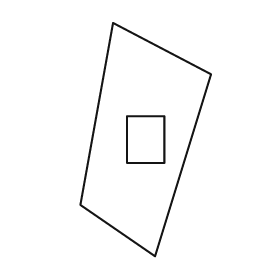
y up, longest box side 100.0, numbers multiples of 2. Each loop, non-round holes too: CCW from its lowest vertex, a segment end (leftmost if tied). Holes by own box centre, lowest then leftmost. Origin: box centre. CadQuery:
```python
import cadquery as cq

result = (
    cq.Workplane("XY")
    .moveTo(4.0, -50.0)
    .lineTo(28.0, 28.0)
    .lineTo(-14.0, 50.0)
    .lineTo(-28.0, -28.0)
    .close()
    .moveTo(-8.0, -10.0)
    .lineTo(8.0, -10.0)
    .lineTo(8.0, 10.0)
    .lineTo(-8.0, 10.0)
    .close()
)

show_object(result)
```